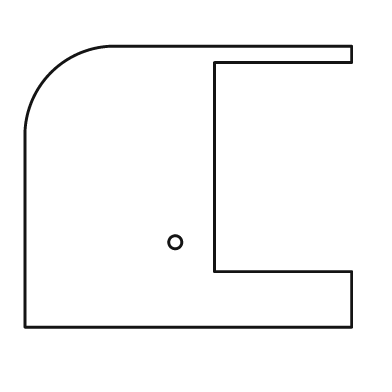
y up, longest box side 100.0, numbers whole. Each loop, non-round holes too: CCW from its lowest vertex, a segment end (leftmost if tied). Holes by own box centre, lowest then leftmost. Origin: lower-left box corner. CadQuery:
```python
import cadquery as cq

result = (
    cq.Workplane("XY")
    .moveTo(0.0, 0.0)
    .lineTo(100.0, 0.0)
    .lineTo(100.0, 17.0)
    .lineTo(58.0, 17.0)
    .lineTo(58.0, 81.0)
    .lineTo(100.0, 81.0)
    .lineTo(100.0, 86.0)
    .lineTo(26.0, 86.0)
    .threePointArc((8.0, 78.0), (0.0, 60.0))
    .close()
    .moveTo(46.0, 26.0)
    .circle(2.0)
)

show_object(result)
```